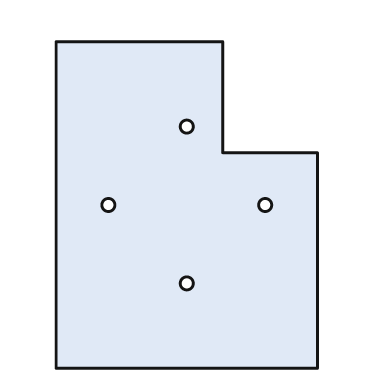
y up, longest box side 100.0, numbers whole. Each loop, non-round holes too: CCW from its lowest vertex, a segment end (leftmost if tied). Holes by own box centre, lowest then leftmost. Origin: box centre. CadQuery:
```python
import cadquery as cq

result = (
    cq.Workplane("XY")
    .moveTo(-40.0, -50.0)
    .lineTo(40.0, -50.0)
    .lineTo(40.0, 16.0)
    .lineTo(11.0, 16.0)
    .lineTo(11.0, 50.0)
    .lineTo(-40.0, 50.0)
    .close()
    .moveTo(0.0, -24.0)
    .circle(2.0)
    .moveTo(-24.0, 0.0)
    .circle(2.0)
    .moveTo(24.0, 0.0)
    .circle(2.0)
    .moveTo(0.0, 24.0)
    .circle(2.0)
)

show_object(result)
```